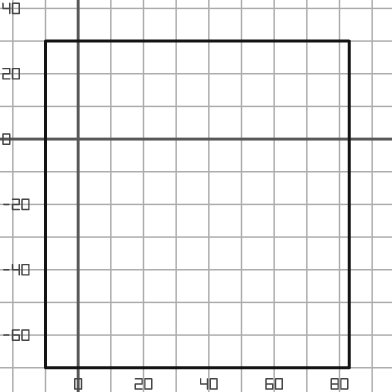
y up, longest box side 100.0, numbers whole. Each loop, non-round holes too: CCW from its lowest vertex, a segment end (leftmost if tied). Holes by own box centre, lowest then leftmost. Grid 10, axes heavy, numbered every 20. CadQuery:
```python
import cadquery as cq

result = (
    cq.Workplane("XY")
    .moveTo(-10.0, -70.0)
    .lineTo(83.0, -70.0)
    .lineTo(83.0, 30.0)
    .lineTo(-10.0, 30.0)
    .close()
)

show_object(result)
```